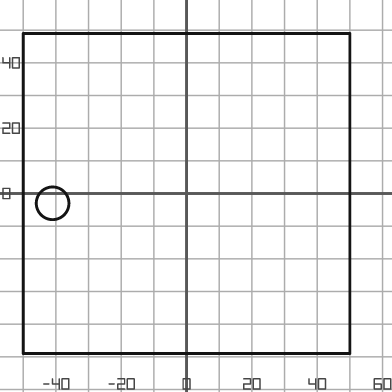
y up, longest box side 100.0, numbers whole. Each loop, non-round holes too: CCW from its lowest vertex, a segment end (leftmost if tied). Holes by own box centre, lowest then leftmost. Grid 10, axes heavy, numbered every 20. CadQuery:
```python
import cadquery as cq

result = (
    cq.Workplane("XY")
    .moveTo(-50.0, -49.0)
    .lineTo(50.0, -49.0)
    .lineTo(50.0, 49.0)
    .lineTo(-50.0, 49.0)
    .close()
    .moveTo(-41.0, -3.0)
    .circle(5.0)
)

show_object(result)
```